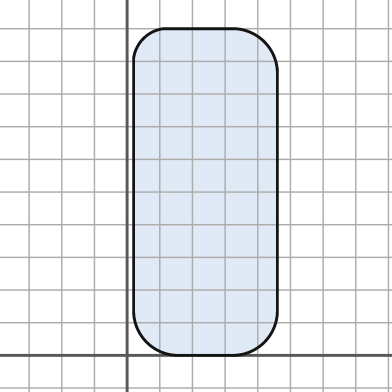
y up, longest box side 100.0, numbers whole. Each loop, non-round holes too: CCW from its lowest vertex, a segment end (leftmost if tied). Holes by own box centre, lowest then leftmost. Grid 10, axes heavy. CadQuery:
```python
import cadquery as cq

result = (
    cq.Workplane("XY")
    .moveTo(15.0, 0.0)
    .lineTo(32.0, 0.0)
    .threePointArc((42.0, 4.0), (46.0, 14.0))
    .lineTo(46.0, 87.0)
    .threePointArc((42.0, 96.0), (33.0, 100.0))
    .lineTo(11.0, 100.0)
    .threePointArc((5.0, 97.0), (2.0, 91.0))
    .lineTo(2.0, 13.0)
    .threePointArc((6.0, 4.0), (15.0, 0.0))
    .close()
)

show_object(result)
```